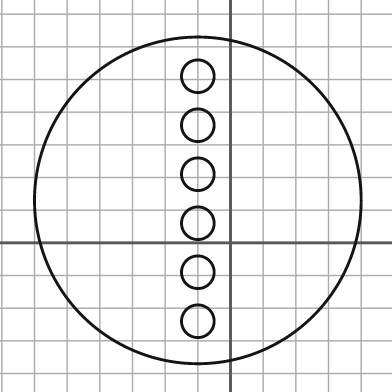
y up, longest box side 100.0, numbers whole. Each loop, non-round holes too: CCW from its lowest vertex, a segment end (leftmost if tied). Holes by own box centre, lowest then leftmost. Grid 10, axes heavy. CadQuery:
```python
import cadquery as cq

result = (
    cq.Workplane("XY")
    .moveTo(-10.0, 13.0)
    .circle(50.0)
    .moveTo(-10.0, -24.0)
    .circle(5.0)
    .moveTo(-10.0, -9.0)
    .circle(5.0)
    .moveTo(-10.0, 6.0)
    .circle(5.0)
    .moveTo(-10.0, 21.0)
    .circle(5.0)
    .moveTo(-10.0, 36.0)
    .circle(5.0)
    .moveTo(-10.0, 51.0)
    .circle(5.0)
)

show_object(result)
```